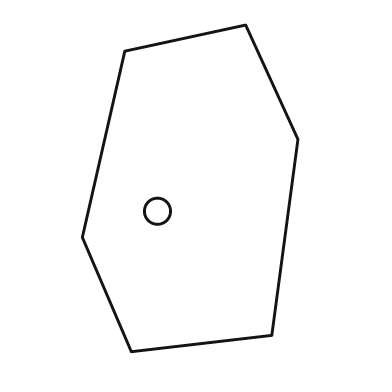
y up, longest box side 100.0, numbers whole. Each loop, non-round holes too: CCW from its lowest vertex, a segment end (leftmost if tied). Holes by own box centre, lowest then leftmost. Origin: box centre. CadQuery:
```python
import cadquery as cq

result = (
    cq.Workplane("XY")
    .moveTo(-18.0, -50.0)
    .lineTo(25.0, -45.0)
    .lineTo(33.0, 15.0)
    .lineTo(17.0, 50.0)
    .lineTo(-20.0, 42.0)
    .lineTo(-33.0, -15.0)
    .close()
    .moveTo(-10.0, -7.0)
    .circle(4.0)
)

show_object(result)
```